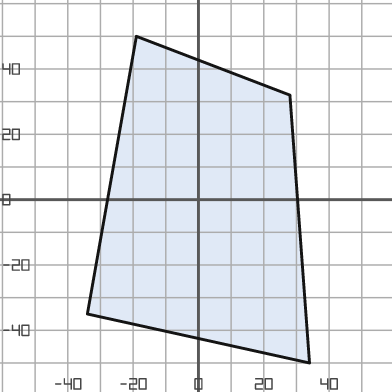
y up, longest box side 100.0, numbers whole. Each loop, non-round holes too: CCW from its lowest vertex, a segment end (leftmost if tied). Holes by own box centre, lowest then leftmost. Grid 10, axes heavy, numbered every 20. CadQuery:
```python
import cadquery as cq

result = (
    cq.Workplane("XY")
    .moveTo(34.0, -50.0)
    .lineTo(28.0, 32.0)
    .lineTo(-19.0, 50.0)
    .lineTo(-34.0, -35.0)
    .close()
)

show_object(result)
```